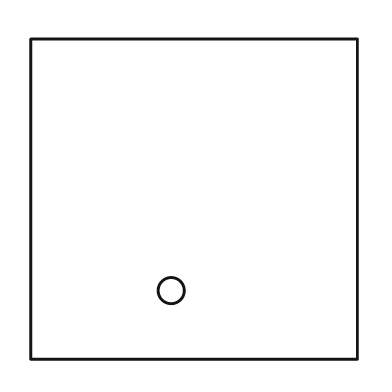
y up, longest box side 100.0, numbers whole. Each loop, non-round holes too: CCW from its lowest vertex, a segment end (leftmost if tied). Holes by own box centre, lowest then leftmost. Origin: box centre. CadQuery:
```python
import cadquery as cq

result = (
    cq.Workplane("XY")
    .moveTo(-50.0, -49.0)
    .lineTo(50.0, -49.0)
    .lineTo(50.0, 49.0)
    .lineTo(-50.0, 49.0)
    .close()
    .moveTo(-7.0, -28.0)
    .circle(4.0)
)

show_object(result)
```